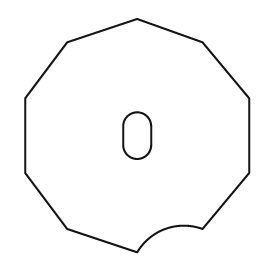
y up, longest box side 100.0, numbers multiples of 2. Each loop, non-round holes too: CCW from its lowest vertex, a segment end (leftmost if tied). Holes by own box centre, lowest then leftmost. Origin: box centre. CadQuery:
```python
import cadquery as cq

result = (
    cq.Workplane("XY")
    .moveTo(0.0, -50.0)
    .threePointArc((12.0, -40.0), (28.0, -40.0))
    .lineTo(48.0, -16.0)
    .lineTo(48.0, 16.0)
    .lineTo(28.0, 40.0)
    .lineTo(0.0, 50.0)
    .lineTo(-30.0, 40.0)
    .lineTo(-48.0, 16.0)
    .lineTo(-48.0, -16.0)
    .lineTo(-30.0, -40.0)
    .close()
    .moveTo(-6.0, -4.0)
    .threePointArc((0.0, -10.0), (6.0, -4.0))
    .lineTo(6.0, 4.0)
    .threePointArc((0.0, 10.0), (-6.0, 4.0))
    .close()
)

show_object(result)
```